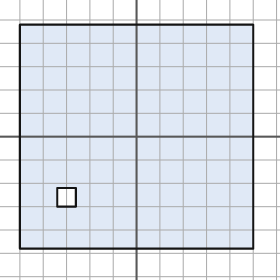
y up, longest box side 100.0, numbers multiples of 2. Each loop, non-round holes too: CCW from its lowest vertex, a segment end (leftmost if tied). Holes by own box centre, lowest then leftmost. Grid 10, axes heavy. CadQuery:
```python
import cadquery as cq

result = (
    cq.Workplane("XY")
    .moveTo(-50.0, -48.0)
    .lineTo(50.0, -48.0)
    .lineTo(50.0, 48.0)
    .lineTo(-50.0, 48.0)
    .close()
    .moveTo(-34.0, -30.0)
    .lineTo(-26.0, -30.0)
    .lineTo(-26.0, -22.0)
    .lineTo(-34.0, -22.0)
    .close()
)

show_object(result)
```